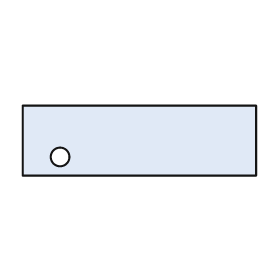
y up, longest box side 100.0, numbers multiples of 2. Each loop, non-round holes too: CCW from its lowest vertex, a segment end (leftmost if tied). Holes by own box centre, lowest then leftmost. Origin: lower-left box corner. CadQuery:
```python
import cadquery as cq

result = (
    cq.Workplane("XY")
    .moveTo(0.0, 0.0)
    .lineTo(100.0, 0.0)
    .lineTo(100.0, 30.0)
    .lineTo(0.0, 30.0)
    .close()
    .moveTo(16.0, 8.0)
    .circle(4.0)
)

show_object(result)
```